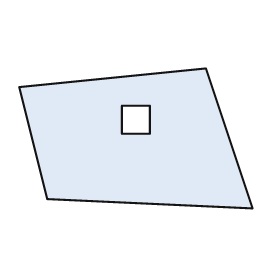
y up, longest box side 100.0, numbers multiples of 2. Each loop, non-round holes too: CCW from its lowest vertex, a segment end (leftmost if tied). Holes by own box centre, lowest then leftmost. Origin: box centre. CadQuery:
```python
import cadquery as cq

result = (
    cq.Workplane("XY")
    .moveTo(50.0, -30.0)
    .lineTo(30.0, 30.0)
    .lineTo(-50.0, 22.0)
    .lineTo(-38.0, -26.0)
    .close()
    .moveTo(-6.0, 2.0)
    .lineTo(6.0, 2.0)
    .lineTo(6.0, 14.0)
    .lineTo(-6.0, 14.0)
    .close()
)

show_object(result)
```